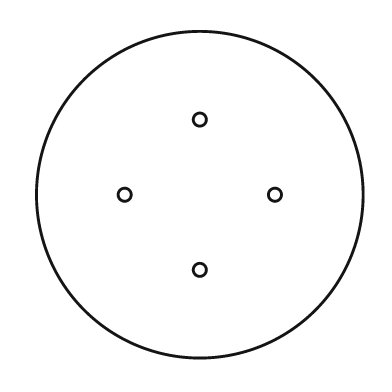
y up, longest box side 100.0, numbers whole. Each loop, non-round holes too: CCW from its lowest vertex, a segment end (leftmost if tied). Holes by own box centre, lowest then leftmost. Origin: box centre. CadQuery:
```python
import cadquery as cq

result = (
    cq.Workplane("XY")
    .moveTo(0.0, 0.0)
    .circle(50.0)
    .moveTo(0.0, -23.0)
    .circle(2.0)
    .moveTo(-23.0, 0.0)
    .circle(2.0)
    .moveTo(23.0, 0.0)
    .circle(2.0)
    .moveTo(0.0, 23.0)
    .circle(2.0)
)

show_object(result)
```